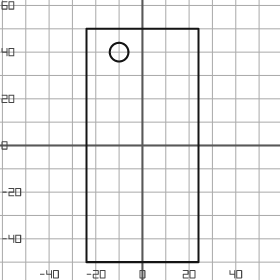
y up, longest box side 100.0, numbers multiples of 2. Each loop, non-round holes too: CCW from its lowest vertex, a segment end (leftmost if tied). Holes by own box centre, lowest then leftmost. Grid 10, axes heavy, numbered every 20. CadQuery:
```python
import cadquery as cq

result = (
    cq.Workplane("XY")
    .moveTo(-24.0, -50.0)
    .lineTo(24.0, -50.0)
    .lineTo(24.0, 50.0)
    .lineTo(-24.0, 50.0)
    .close()
    .moveTo(-10.0, 40.0)
    .circle(4.0)
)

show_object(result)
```